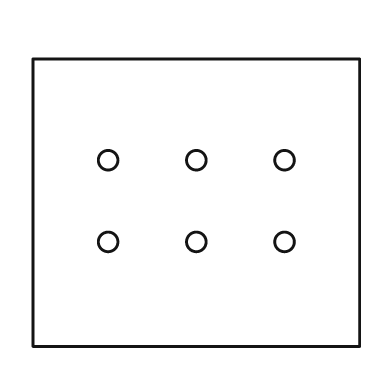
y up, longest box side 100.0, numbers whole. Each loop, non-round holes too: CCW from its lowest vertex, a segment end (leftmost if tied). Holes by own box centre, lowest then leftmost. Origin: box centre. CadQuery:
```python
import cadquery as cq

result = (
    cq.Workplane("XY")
    .moveTo(-50.0, -44.0)
    .lineTo(50.0, -44.0)
    .lineTo(50.0, 44.0)
    .lineTo(-50.0, 44.0)
    .close()
    .moveTo(-27.0, -12.0)
    .circle(3.0)
    .moveTo(0.0, -12.0)
    .circle(3.0)
    .moveTo(27.0, -12.0)
    .circle(3.0)
    .moveTo(-27.0, 13.0)
    .circle(3.0)
    .moveTo(0.0, 13.0)
    .circle(3.0)
    .moveTo(27.0, 13.0)
    .circle(3.0)
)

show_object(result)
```